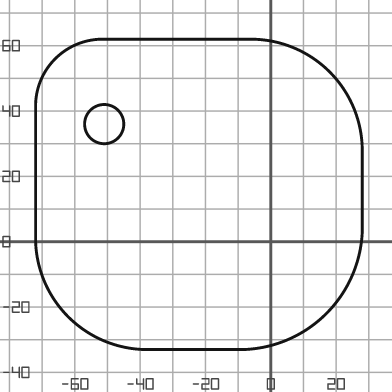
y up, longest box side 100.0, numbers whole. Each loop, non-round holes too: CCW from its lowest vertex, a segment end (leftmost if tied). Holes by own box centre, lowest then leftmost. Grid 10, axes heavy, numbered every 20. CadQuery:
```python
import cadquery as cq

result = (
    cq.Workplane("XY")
    .moveTo(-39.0, -33.0)
    .lineTo(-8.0, -33.0)
    .threePointArc((17.0, -22.0), (28.0, 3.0))
    .lineTo(28.0, 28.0)
    .threePointArc((18.0, 52.0), (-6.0, 62.0))
    .lineTo(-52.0, 62.0)
    .threePointArc((-66.0, 56.0), (-72.0, 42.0))
    .lineTo(-72.0, 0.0)
    .threePointArc((-62.0, -23.0), (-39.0, -33.0))
    .close()
    .moveTo(-51.0, 36.0)
    .circle(6.0)
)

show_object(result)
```